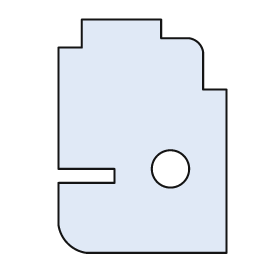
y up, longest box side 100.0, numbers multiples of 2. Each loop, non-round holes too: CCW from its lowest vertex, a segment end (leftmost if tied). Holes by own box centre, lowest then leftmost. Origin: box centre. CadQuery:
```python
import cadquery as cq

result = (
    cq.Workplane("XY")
    .moveTo(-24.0, -50.0)
    .lineTo(36.0, -50.0)
    .lineTo(36.0, 20.0)
    .lineTo(26.0, 20.0)
    .lineTo(26.0, 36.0)
    .threePointArc((24.0, 40.0), (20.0, 42.0))
    .lineTo(8.0, 42.0)
    .lineTo(8.0, 50.0)
    .lineTo(-26.0, 50.0)
    .lineTo(-26.0, 38.0)
    .lineTo(-36.0, 38.0)
    .lineTo(-36.0, -14.0)
    .lineTo(-12.0, -14.0)
    .lineTo(-12.0, -20.0)
    .lineTo(-36.0, -20.0)
    .lineTo(-36.0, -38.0)
    .threePointArc((-32.0, -46.0), (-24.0, -50.0))
    .close()
    .moveTo(12.0, -14.0)
    .circle(8.0)
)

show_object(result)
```